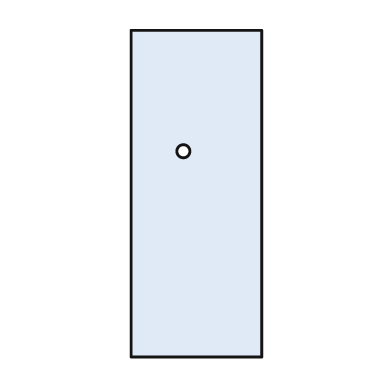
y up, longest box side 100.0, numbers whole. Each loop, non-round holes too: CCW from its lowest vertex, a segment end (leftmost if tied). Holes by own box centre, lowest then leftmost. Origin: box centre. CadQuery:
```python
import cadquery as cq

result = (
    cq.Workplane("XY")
    .moveTo(-20.0, -50.0)
    .lineTo(20.0, -50.0)
    .lineTo(20.0, 50.0)
    .lineTo(-20.0, 50.0)
    .close()
    .moveTo(-4.0, 13.0)
    .circle(2.0)
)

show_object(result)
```